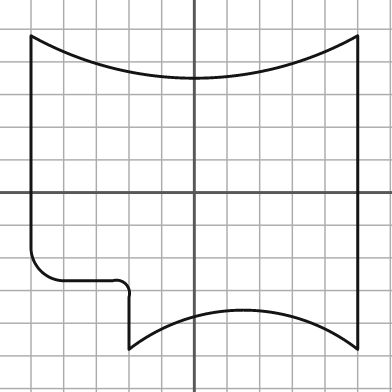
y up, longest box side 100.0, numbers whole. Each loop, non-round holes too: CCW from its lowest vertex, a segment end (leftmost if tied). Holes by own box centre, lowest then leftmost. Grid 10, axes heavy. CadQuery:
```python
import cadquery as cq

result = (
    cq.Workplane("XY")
    .moveTo(-20.0, -48.0)
    .threePointArc((15.0, -36.0), (50.0, -48.0))
    .lineTo(50.0, 48.0)
    .threePointArc((0.0, 35.0), (-50.0, 48.0))
    .lineTo(-50.0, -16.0)
    .threePointArc((-47.0, -24.0), (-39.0, -27.0))
    .lineTo(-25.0, -27.0)
    .threePointArc((-21.0, -28.0), (-20.0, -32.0))
    .close()
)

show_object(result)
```